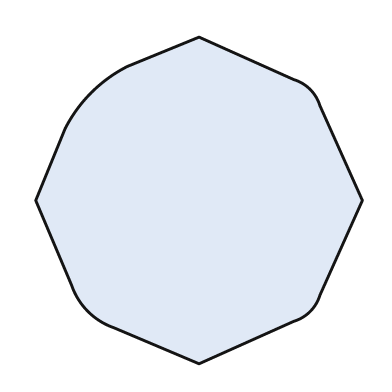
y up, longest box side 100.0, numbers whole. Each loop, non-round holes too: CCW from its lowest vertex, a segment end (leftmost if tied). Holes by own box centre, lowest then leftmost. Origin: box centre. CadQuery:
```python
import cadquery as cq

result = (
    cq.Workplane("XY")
    .moveTo(0.0, -50.0)
    .lineTo(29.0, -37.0)
    .threePointArc((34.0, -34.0), (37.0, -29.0))
    .lineTo(50.0, 0.0)
    .lineTo(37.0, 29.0)
    .threePointArc((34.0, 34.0), (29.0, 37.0))
    .lineTo(0.0, 50.0)
    .lineTo(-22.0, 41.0)
    .threePointArc((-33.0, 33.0), (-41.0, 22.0))
    .lineTo(-50.0, 0.0)
    .lineTo(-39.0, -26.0)
    .threePointArc((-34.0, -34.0), (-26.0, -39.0))
    .close()
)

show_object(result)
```